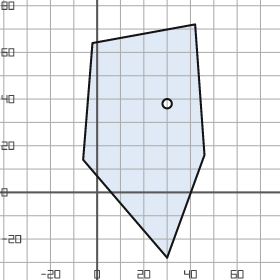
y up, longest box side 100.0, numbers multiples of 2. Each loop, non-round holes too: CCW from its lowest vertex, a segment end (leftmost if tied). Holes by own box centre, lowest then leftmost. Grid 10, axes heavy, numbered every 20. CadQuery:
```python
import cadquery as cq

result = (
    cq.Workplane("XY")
    .moveTo(30.0, -28.0)
    .lineTo(46.0, 16.0)
    .lineTo(42.0, 72.0)
    .lineTo(-2.0, 64.0)
    .lineTo(-6.0, 14.0)
    .close()
    .moveTo(30.0, 38.0)
    .circle(2.0)
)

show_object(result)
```